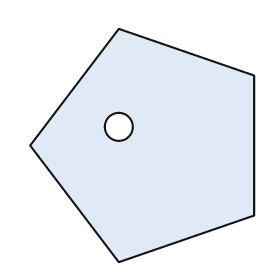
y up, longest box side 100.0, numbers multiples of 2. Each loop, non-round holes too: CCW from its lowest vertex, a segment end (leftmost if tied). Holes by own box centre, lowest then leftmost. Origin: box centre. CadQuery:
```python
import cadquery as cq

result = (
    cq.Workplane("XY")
    .moveTo(-10.0, -50.0)
    .lineTo(48.0, -30.0)
    .lineTo(48.0, 30.0)
    .lineTo(-10.0, 50.0)
    .lineTo(-48.0, 0.0)
    .close()
    .moveTo(-10.0, 8.0)
    .circle(6.0)
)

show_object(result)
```